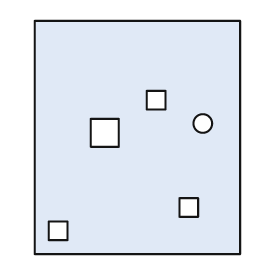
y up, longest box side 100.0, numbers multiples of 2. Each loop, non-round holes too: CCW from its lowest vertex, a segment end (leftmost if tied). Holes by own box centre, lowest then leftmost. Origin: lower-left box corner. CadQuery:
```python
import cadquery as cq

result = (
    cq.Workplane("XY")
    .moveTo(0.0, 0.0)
    .lineTo(88.0, 0.0)
    .lineTo(88.0, 100.0)
    .lineTo(0.0, 100.0)
    .close()
    .moveTo(6.0, 6.0)
    .lineTo(14.0, 6.0)
    .lineTo(14.0, 14.0)
    .lineTo(6.0, 14.0)
    .close()
    .moveTo(62.0, 16.0)
    .lineTo(70.0, 16.0)
    .lineTo(70.0, 24.0)
    .lineTo(62.0, 24.0)
    .close()
    .moveTo(24.0, 46.0)
    .lineTo(36.0, 46.0)
    .lineTo(36.0, 58.0)
    .lineTo(24.0, 58.0)
    .close()
    .moveTo(72.0, 56.0)
    .circle(4.0)
    .moveTo(48.0, 62.0)
    .lineTo(56.0, 62.0)
    .lineTo(56.0, 70.0)
    .lineTo(48.0, 70.0)
    .close()
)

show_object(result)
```